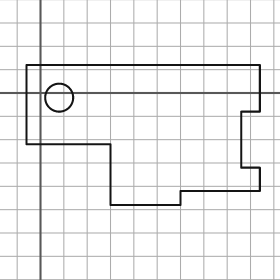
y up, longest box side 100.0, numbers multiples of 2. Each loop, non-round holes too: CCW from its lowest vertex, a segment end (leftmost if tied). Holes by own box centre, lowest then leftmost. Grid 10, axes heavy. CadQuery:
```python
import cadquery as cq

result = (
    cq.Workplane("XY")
    .moveTo(30.0, -48.0)
    .lineTo(60.0, -48.0)
    .lineTo(60.0, -42.0)
    .lineTo(94.0, -42.0)
    .lineTo(94.0, -32.0)
    .lineTo(86.0, -32.0)
    .lineTo(86.0, -8.0)
    .lineTo(94.0, -8.0)
    .lineTo(94.0, 12.0)
    .lineTo(-6.0, 12.0)
    .lineTo(-6.0, -22.0)
    .lineTo(30.0, -22.0)
    .close()
    .moveTo(8.0, -2.0)
    .circle(6.0)
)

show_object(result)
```